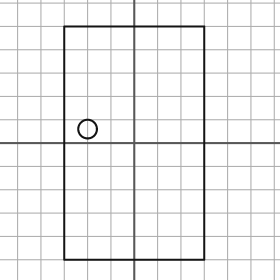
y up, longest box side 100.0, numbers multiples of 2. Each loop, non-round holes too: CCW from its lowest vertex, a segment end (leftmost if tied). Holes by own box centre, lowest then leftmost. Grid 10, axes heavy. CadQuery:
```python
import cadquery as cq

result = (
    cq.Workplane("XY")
    .moveTo(-30.0, -50.0)
    .lineTo(30.0, -50.0)
    .lineTo(30.0, 50.0)
    .lineTo(-30.0, 50.0)
    .close()
    .moveTo(-20.0, 6.0)
    .circle(4.0)
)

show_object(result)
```